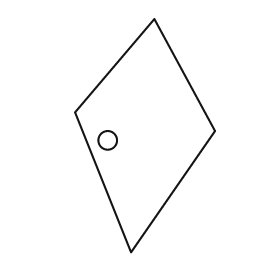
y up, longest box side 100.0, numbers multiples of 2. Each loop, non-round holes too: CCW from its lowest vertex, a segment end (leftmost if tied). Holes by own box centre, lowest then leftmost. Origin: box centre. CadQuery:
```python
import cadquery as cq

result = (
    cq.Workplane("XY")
    .moveTo(-6.0, -50.0)
    .lineTo(30.0, 2.0)
    .lineTo(4.0, 50.0)
    .lineTo(-30.0, 10.0)
    .close()
    .moveTo(-16.0, -2.0)
    .circle(4.0)
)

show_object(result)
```